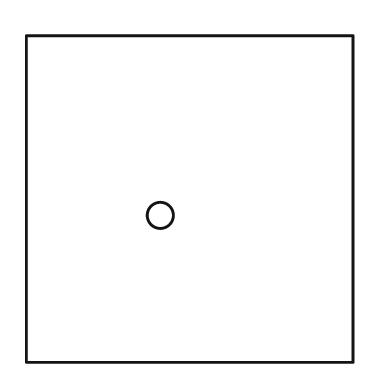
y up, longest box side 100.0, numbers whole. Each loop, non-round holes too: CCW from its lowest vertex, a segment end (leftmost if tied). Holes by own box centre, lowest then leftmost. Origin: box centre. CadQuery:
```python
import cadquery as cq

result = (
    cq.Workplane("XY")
    .moveTo(-50.0, -50.0)
    .lineTo(50.0, -50.0)
    .lineTo(50.0, 50.0)
    .lineTo(-50.0, 50.0)
    .close()
    .moveTo(-9.0, -5.0)
    .circle(4.0)
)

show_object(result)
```